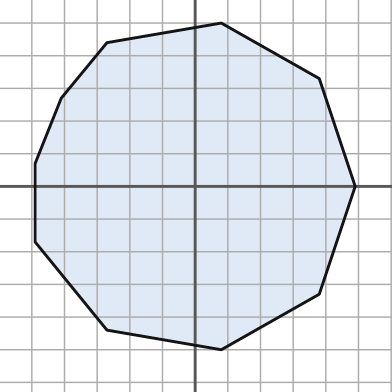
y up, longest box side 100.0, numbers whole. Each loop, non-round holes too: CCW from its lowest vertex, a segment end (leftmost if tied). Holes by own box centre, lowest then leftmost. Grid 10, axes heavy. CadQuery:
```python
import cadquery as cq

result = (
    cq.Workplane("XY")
    .moveTo(8.0, -50.0)
    .lineTo(38.0, -33.0)
    .lineTo(49.0, 0.0)
    .lineTo(38.0, 33.0)
    .lineTo(8.0, 50.0)
    .lineTo(-27.0, 44.0)
    .lineTo(-41.0, 27.0)
    .lineTo(-49.0, 7.0)
    .lineTo(-49.0, -17.0)
    .lineTo(-27.0, -44.0)
    .close()
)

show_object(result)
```